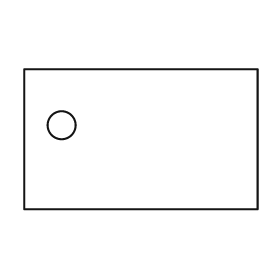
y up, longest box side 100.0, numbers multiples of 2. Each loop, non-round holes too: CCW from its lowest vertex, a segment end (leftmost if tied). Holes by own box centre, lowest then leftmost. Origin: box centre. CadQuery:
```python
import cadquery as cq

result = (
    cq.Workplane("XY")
    .moveTo(-50.0, -30.0)
    .lineTo(50.0, -30.0)
    .lineTo(50.0, 30.0)
    .lineTo(-50.0, 30.0)
    .close()
    .moveTo(-34.0, 6.0)
    .circle(6.0)
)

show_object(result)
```